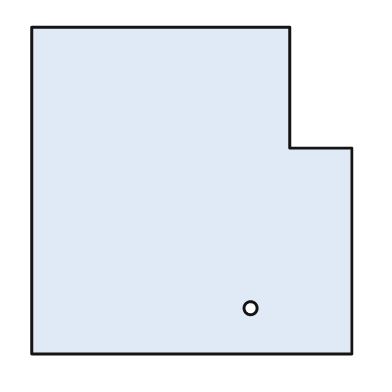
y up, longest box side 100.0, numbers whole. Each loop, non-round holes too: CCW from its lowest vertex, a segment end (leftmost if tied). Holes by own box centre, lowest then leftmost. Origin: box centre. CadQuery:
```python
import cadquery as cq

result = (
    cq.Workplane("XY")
    .moveTo(-49.0, -50.0)
    .lineTo(49.0, -50.0)
    .lineTo(49.0, 13.0)
    .lineTo(30.0, 13.0)
    .lineTo(30.0, 50.0)
    .lineTo(-49.0, 50.0)
    .close()
    .moveTo(18.0, -36.0)
    .circle(2.0)
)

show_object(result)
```